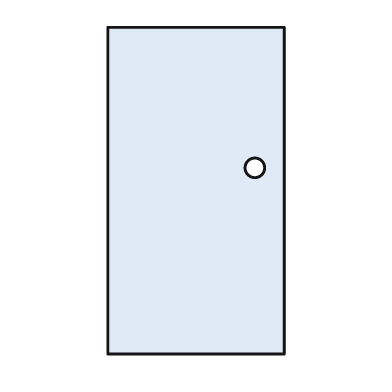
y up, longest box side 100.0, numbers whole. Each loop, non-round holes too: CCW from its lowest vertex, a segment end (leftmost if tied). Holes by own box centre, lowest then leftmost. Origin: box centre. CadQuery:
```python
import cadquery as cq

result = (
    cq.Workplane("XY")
    .moveTo(-27.0, -50.0)
    .lineTo(27.0, -50.0)
    .lineTo(27.0, 50.0)
    .lineTo(-27.0, 50.0)
    .close()
    .moveTo(18.0, 7.0)
    .circle(3.0)
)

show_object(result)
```